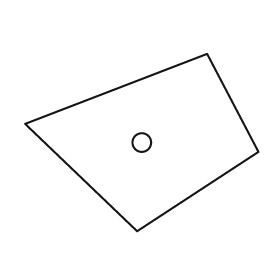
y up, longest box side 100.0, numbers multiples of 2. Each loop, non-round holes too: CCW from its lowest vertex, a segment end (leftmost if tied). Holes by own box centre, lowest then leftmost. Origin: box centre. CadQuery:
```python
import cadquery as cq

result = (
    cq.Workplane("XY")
    .moveTo(-2.0, -38.0)
    .lineTo(50.0, -4.0)
    .lineTo(28.0, 38.0)
    .lineTo(-50.0, 8.0)
    .close()
    .moveTo(0.0, 0.0)
    .circle(4.0)
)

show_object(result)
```